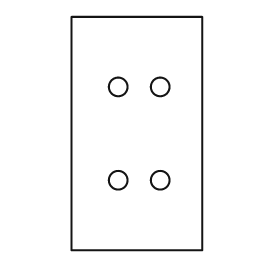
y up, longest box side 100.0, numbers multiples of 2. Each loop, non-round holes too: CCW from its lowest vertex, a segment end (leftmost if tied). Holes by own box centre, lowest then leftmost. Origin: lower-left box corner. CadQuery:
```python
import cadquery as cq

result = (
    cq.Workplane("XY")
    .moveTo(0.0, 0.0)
    .lineTo(56.0, 0.0)
    .lineTo(56.0, 100.0)
    .lineTo(0.0, 100.0)
    .close()
    .moveTo(20.0, 30.0)
    .circle(4.0)
    .moveTo(38.0, 30.0)
    .circle(4.0)
    .moveTo(20.0, 70.0)
    .circle(4.0)
    .moveTo(38.0, 70.0)
    .circle(4.0)
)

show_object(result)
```